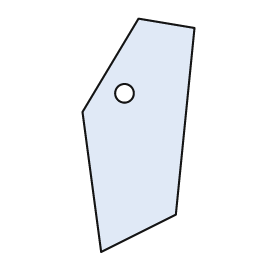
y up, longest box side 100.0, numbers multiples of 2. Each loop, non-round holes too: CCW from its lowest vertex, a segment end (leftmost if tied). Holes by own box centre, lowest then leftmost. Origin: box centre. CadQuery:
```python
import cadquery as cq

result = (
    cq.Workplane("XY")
    .moveTo(-16.0, -50.0)
    .lineTo(16.0, -34.0)
    .lineTo(24.0, 46.0)
    .lineTo(0.0, 50.0)
    .lineTo(-24.0, 10.0)
    .close()
    .moveTo(-6.0, 18.0)
    .circle(4.0)
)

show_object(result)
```